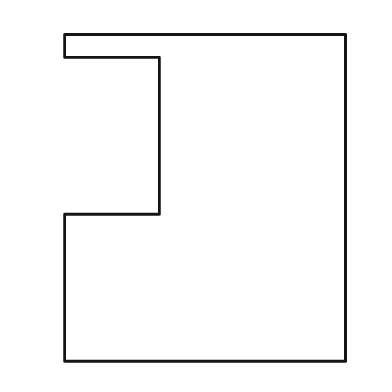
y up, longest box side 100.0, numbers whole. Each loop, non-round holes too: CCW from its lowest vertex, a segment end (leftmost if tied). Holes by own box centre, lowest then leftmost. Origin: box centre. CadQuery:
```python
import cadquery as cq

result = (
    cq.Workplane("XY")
    .moveTo(-43.0, -50.0)
    .lineTo(43.0, -50.0)
    .lineTo(43.0, 50.0)
    .lineTo(-43.0, 50.0)
    .lineTo(-43.0, 43.0)
    .lineTo(-14.0, 43.0)
    .lineTo(-14.0, -5.0)
    .lineTo(-43.0, -5.0)
    .close()
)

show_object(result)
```